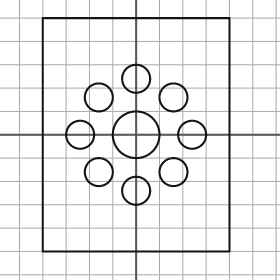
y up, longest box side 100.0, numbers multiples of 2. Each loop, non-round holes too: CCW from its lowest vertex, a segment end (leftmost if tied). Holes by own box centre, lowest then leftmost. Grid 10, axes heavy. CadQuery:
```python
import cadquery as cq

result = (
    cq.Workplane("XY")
    .moveTo(-40.0, -50.0)
    .lineTo(40.0, -50.0)
    .lineTo(40.0, 50.0)
    .lineTo(-40.0, 50.0)
    .close()
    .moveTo(0.0, -24.0)
    .circle(6.0)
    .moveTo(-16.0, -16.0)
    .circle(6.0)
    .moveTo(16.0, -16.0)
    .circle(6.0)
    .moveTo(-24.0, 0.0)
    .circle(6.0)
    .moveTo(0.0, 0.0)
    .circle(10.0)
    .moveTo(24.0, 0.0)
    .circle(6.0)
    .moveTo(-16.0, 16.0)
    .circle(6.0)
    .moveTo(16.0, 16.0)
    .circle(6.0)
    .moveTo(0.0, 24.0)
    .circle(6.0)
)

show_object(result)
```